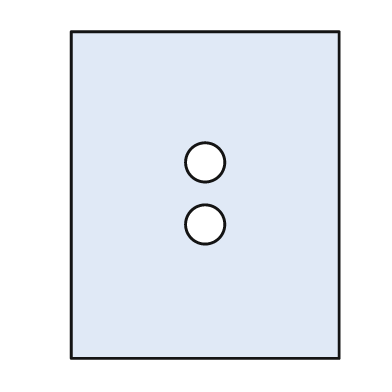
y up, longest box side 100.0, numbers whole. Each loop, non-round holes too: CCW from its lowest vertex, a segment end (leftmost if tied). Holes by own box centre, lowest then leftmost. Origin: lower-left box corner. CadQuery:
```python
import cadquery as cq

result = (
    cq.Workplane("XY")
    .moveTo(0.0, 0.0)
    .lineTo(82.0, 0.0)
    .lineTo(82.0, 100.0)
    .lineTo(0.0, 100.0)
    .close()
    .moveTo(41.0, 41.0)
    .circle(6.0)
    .moveTo(41.0, 60.0)
    .circle(6.0)
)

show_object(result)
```